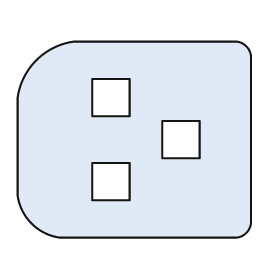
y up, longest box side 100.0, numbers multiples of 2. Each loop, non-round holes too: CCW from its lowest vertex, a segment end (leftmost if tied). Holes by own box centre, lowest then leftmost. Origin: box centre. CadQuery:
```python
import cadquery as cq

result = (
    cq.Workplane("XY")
    .moveTo(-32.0, -42.0)
    .lineTo(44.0, -42.0)
    .threePointArc((48.0, -40.0), (50.0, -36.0))
    .lineTo(50.0, 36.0)
    .threePointArc((48.0, 40.0), (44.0, 42.0))
    .lineTo(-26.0, 42.0)
    .threePointArc((-42.0, 34.0), (-50.0, 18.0))
    .lineTo(-50.0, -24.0)
    .threePointArc((-44.0, -36.0), (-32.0, -42.0))
    .close()
    .moveTo(-18.0, -26.0)
    .lineTo(-2.0, -26.0)
    .lineTo(-2.0, -10.0)
    .lineTo(-18.0, -10.0)
    .close()
    .moveTo(12.0, -8.0)
    .lineTo(28.0, -8.0)
    .lineTo(28.0, 8.0)
    .lineTo(12.0, 8.0)
    .close()
    .moveTo(-18.0, 10.0)
    .lineTo(-2.0, 10.0)
    .lineTo(-2.0, 26.0)
    .lineTo(-18.0, 26.0)
    .close()
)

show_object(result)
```